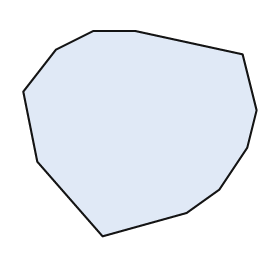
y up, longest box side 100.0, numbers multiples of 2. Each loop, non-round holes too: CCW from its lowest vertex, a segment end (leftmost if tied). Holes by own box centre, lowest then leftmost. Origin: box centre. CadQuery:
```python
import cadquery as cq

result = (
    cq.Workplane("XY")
    .moveTo(-16.0, -44.0)
    .lineTo(20.0, -34.0)
    .lineTo(34.0, -24.0)
    .lineTo(46.0, -6.0)
    .lineTo(50.0, 10.0)
    .lineTo(44.0, 34.0)
    .lineTo(-2.0, 44.0)
    .lineTo(-20.0, 44.0)
    .lineTo(-36.0, 36.0)
    .lineTo(-50.0, 18.0)
    .lineTo(-44.0, -12.0)
    .close()
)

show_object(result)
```